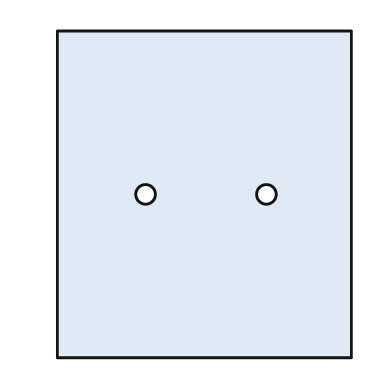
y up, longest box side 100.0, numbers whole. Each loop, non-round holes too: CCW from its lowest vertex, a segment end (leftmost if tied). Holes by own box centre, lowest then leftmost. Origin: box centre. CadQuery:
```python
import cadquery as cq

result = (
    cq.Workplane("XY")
    .moveTo(-45.0, -50.0)
    .lineTo(45.0, -50.0)
    .lineTo(45.0, 50.0)
    .lineTo(-45.0, 50.0)
    .close()
    .moveTo(-18.0, 0.0)
    .circle(3.0)
    .moveTo(19.0, 0.0)
    .circle(3.0)
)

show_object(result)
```